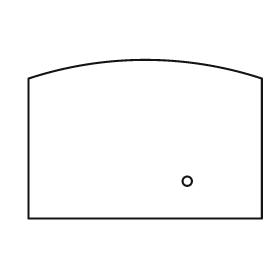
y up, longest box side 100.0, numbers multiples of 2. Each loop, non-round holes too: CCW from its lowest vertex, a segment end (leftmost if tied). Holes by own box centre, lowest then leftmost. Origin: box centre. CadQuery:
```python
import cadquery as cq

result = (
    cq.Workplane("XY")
    .moveTo(-50.0, -34.0)
    .lineTo(50.0, -34.0)
    .lineTo(50.0, 26.0)
    .threePointArc((0.0, 34.0), (-50.0, 26.0))
    .close()
    .moveTo(18.0, -18.0)
    .circle(2.0)
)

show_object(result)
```